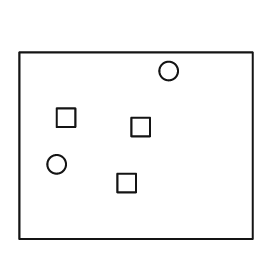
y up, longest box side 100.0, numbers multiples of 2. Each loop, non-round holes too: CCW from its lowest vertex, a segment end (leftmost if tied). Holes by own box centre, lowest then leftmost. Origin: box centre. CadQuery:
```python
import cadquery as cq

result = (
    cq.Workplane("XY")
    .moveTo(-50.0, -40.0)
    .lineTo(50.0, -40.0)
    .lineTo(50.0, 40.0)
    .lineTo(-50.0, 40.0)
    .close()
    .moveTo(-8.0, -20.0)
    .lineTo(0.0, -20.0)
    .lineTo(0.0, -12.0)
    .lineTo(-8.0, -12.0)
    .close()
    .moveTo(-34.0, -8.0)
    .circle(4.0)
    .moveTo(-2.0, 4.0)
    .lineTo(6.0, 4.0)
    .lineTo(6.0, 12.0)
    .lineTo(-2.0, 12.0)
    .close()
    .moveTo(-34.0, 8.0)
    .lineTo(-26.0, 8.0)
    .lineTo(-26.0, 16.0)
    .lineTo(-34.0, 16.0)
    .close()
    .moveTo(14.0, 32.0)
    .circle(4.0)
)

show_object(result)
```